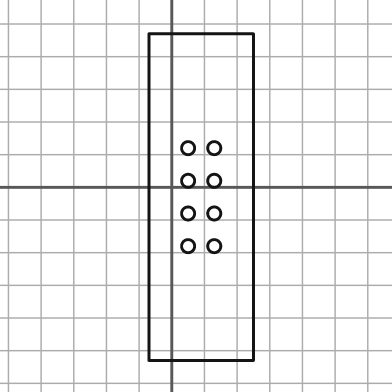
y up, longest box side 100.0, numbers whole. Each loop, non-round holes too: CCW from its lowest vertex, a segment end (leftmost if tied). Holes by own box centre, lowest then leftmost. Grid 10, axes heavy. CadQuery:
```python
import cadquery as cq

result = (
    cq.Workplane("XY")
    .moveTo(-7.0, -53.0)
    .lineTo(25.0, -53.0)
    .lineTo(25.0, 47.0)
    .lineTo(-7.0, 47.0)
    .close()
    .moveTo(5.0, -18.0)
    .circle(2.0)
    .moveTo(13.0, -18.0)
    .circle(2.0)
    .moveTo(5.0, -8.0)
    .circle(2.0)
    .moveTo(13.0, -8.0)
    .circle(2.0)
    .moveTo(5.0, 2.0)
    .circle(2.0)
    .moveTo(13.0, 2.0)
    .circle(2.0)
    .moveTo(5.0, 12.0)
    .circle(2.0)
    .moveTo(13.0, 12.0)
    .circle(2.0)
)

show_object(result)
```